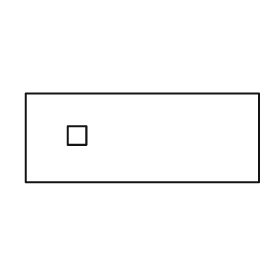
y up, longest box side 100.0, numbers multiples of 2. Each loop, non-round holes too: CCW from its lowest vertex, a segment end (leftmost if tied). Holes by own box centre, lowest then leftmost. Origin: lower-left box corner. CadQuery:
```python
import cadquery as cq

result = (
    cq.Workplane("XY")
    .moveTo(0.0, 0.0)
    .lineTo(100.0, 0.0)
    .lineTo(100.0, 38.0)
    .lineTo(0.0, 38.0)
    .close()
    .moveTo(18.0, 16.0)
    .lineTo(26.0, 16.0)
    .lineTo(26.0, 24.0)
    .lineTo(18.0, 24.0)
    .close()
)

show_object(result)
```